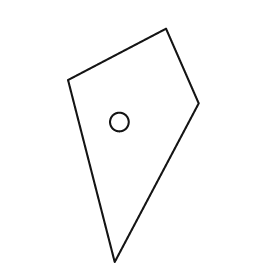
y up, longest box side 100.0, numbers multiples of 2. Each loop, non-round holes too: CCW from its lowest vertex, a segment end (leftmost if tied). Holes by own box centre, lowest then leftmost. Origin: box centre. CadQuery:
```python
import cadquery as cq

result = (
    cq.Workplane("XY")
    .moveTo(-8.0, -50.0)
    .lineTo(28.0, 18.0)
    .lineTo(14.0, 50.0)
    .lineTo(-28.0, 28.0)
    .close()
    .moveTo(-6.0, 10.0)
    .circle(4.0)
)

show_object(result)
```